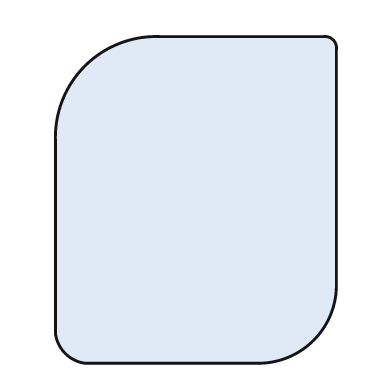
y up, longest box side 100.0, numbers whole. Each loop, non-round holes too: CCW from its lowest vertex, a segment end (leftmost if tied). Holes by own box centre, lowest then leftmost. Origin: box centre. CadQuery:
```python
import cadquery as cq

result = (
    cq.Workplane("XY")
    .moveTo(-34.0, -50.0)
    .lineTo(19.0, -50.0)
    .threePointArc((36.0, -43.0), (43.0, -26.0))
    .lineTo(43.0, 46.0)
    .threePointArc((42.0, 49.0), (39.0, 50.0))
    .lineTo(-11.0, 50.0)
    .threePointArc((-34.0, 41.0), (-43.0, 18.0))
    .lineTo(-43.0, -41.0)
    .threePointArc((-40.0, -47.0), (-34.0, -50.0))
    .close()
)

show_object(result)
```